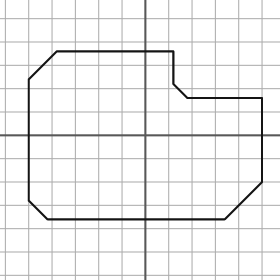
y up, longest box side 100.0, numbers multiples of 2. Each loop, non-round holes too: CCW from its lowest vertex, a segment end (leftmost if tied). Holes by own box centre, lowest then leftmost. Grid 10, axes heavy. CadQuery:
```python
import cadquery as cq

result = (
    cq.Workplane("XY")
    .moveTo(-42.0, -36.0)
    .lineTo(34.0, -36.0)
    .lineTo(50.0, -20.0)
    .lineTo(50.0, 16.0)
    .lineTo(18.0, 16.0)
    .lineTo(12.0, 22.0)
    .lineTo(12.0, 36.0)
    .lineTo(-38.0, 36.0)
    .lineTo(-50.0, 24.0)
    .lineTo(-50.0, -28.0)
    .close()
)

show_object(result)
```